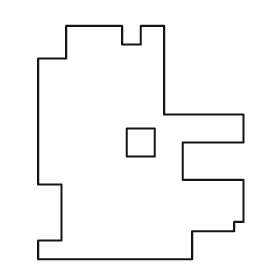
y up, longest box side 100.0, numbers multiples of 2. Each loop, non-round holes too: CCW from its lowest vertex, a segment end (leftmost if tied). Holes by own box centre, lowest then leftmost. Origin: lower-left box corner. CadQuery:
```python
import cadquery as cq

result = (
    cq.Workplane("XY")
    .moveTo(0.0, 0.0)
    .lineTo(66.0, 0.0)
    .lineTo(66.0, 12.0)
    .lineTo(84.0, 12.0)
    .lineTo(84.0, 16.0)
    .lineTo(88.0, 16.0)
    .lineTo(88.0, 34.0)
    .lineTo(62.0, 34.0)
    .lineTo(62.0, 50.0)
    .lineTo(88.0, 50.0)
    .lineTo(88.0, 62.0)
    .lineTo(54.0, 62.0)
    .lineTo(54.0, 100.0)
    .lineTo(44.0, 100.0)
    .lineTo(44.0, 92.0)
    .lineTo(36.0, 92.0)
    .lineTo(36.0, 100.0)
    .lineTo(12.0, 100.0)
    .lineTo(12.0, 86.0)
    .lineTo(0.0, 86.0)
    .lineTo(0.0, 32.0)
    .lineTo(10.0, 32.0)
    .lineTo(10.0, 8.0)
    .lineTo(0.0, 8.0)
    .close()
    .moveTo(38.0, 44.0)
    .lineTo(50.0, 44.0)
    .lineTo(50.0, 56.0)
    .lineTo(38.0, 56.0)
    .close()
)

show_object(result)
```